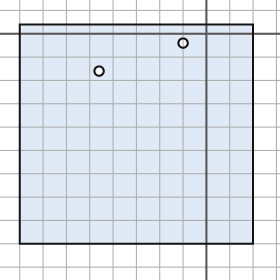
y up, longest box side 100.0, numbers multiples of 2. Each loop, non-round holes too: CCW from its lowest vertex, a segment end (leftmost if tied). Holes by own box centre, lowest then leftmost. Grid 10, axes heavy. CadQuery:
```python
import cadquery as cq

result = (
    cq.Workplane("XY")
    .moveTo(-80.0, -90.0)
    .lineTo(20.0, -90.0)
    .lineTo(20.0, 4.0)
    .lineTo(-80.0, 4.0)
    .close()
    .moveTo(-46.0, -16.0)
    .circle(2.0)
    .moveTo(-10.0, -4.0)
    .circle(2.0)
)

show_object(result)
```